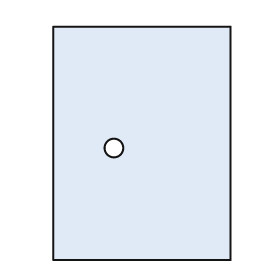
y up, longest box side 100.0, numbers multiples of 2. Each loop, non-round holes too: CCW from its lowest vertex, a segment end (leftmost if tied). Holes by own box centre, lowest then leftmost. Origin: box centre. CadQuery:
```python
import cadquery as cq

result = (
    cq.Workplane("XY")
    .moveTo(-38.0, -50.0)
    .lineTo(38.0, -50.0)
    .lineTo(38.0, 50.0)
    .lineTo(-38.0, 50.0)
    .close()
    .moveTo(-12.0, -2.0)
    .circle(4.0)
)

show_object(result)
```